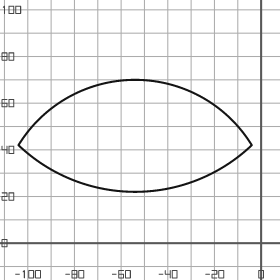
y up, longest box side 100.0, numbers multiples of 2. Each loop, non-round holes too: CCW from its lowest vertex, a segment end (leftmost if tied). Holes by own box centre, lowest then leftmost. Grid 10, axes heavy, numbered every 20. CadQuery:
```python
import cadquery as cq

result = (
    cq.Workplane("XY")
    .moveTo(-104.0, 42.0)
    .threePointArc((-54.0, 22.0), (-4.0, 42.0))
    .threePointArc((-54.0, 70.0), (-104.0, 42.0))
    .close()
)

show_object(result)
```